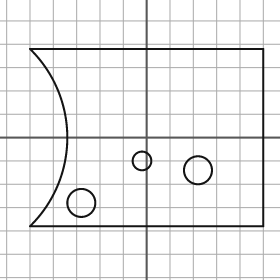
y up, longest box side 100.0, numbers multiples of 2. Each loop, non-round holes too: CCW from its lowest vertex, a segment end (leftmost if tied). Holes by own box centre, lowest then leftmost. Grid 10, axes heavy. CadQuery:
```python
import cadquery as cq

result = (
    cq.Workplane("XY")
    .moveTo(-50.0, -38.0)
    .lineTo(50.0, -38.0)
    .lineTo(50.0, 38.0)
    .lineTo(-50.0, 38.0)
    .threePointArc((-34.0, 0.0), (-50.0, -38.0))
    .close()
    .moveTo(-28.0, -28.0)
    .circle(6.0)
    .moveTo(22.0, -14.0)
    .circle(6.0)
    .moveTo(-2.0, -10.0)
    .circle(4.0)
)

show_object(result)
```